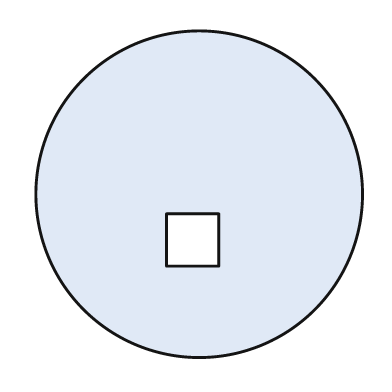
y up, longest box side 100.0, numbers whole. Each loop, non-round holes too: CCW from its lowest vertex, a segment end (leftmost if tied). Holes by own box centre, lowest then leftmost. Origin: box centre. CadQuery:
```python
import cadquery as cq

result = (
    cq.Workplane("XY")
    .moveTo(0.0, 0.0)
    .circle(50.0)
    .moveTo(-10.0, -22.0)
    .lineTo(6.0, -22.0)
    .lineTo(6.0, -6.0)
    .lineTo(-10.0, -6.0)
    .close()
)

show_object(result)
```